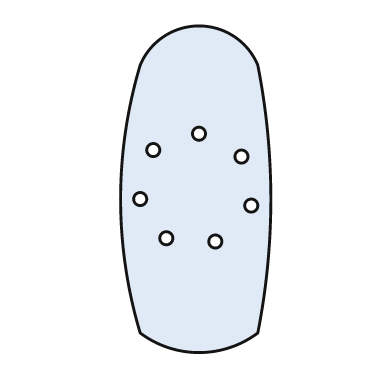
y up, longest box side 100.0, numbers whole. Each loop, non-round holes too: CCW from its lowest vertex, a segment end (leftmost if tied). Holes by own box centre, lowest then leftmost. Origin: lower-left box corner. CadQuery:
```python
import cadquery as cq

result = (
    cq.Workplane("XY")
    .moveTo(6.0, 6.0)
    .threePointArc((24.0, 0.0), (42.0, 6.0))
    .threePointArc((46.0, 47.0), (42.0, 88.0))
    .threePointArc((24.0, 100.0), (6.0, 88.0))
    .threePointArc((0.0, 47.0), (6.0, 6.0))
    .close()
    .moveTo(29.0, 34.0)
    .circle(2.0)
    .moveTo(14.0, 35.0)
    .circle(2.0)
    .moveTo(40.0, 45.0)
    .circle(2.0)
    .moveTo(6.0, 47.0)
    .circle(2.0)
    .moveTo(37.0, 60.0)
    .circle(2.0)
    .moveTo(10.0, 62.0)
    .circle(2.0)
    .moveTo(24.0, 67.0)
    .circle(2.0)
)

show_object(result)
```